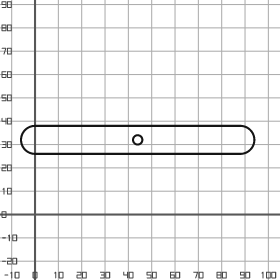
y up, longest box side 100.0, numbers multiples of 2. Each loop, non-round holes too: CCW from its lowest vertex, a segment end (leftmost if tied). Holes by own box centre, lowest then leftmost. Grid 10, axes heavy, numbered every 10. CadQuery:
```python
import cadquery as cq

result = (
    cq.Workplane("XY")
    .moveTo(0.0, 26.0)
    .lineTo(88.0, 26.0)
    .threePointArc((94.0, 32.0), (88.0, 38.0))
    .lineTo(0.0, 38.0)
    .threePointArc((-6.0, 32.0), (0.0, 26.0))
    .close()
    .moveTo(44.0, 32.0)
    .circle(2.0)
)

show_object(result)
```